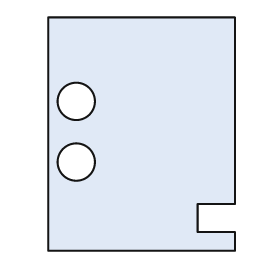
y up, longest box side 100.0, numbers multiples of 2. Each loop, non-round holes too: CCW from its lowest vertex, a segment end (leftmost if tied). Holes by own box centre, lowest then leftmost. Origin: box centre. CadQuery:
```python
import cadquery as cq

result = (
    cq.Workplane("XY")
    .moveTo(-40.0, -50.0)
    .lineTo(40.0, -50.0)
    .lineTo(40.0, -42.0)
    .lineTo(24.0, -42.0)
    .lineTo(24.0, -30.0)
    .lineTo(40.0, -30.0)
    .lineTo(40.0, 50.0)
    .lineTo(-40.0, 50.0)
    .close()
    .moveTo(-28.0, -12.0)
    .circle(8.0)
    .moveTo(-28.0, 14.0)
    .circle(8.0)
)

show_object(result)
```